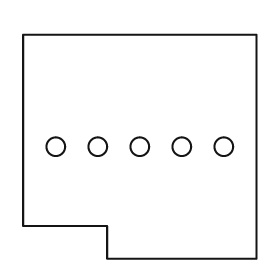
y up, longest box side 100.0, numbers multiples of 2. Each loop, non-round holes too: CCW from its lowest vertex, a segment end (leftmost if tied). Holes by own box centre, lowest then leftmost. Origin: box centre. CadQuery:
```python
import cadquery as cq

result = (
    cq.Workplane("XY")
    .moveTo(-14.0, -48.0)
    .lineTo(50.0, -48.0)
    .lineTo(50.0, 48.0)
    .lineTo(-50.0, 48.0)
    .lineTo(-50.0, -34.0)
    .lineTo(-14.0, -34.0)
    .close()
    .moveTo(-36.0, 0.0)
    .circle(4.0)
    .moveTo(-18.0, 0.0)
    .circle(4.0)
    .moveTo(0.0, 0.0)
    .circle(4.0)
    .moveTo(18.0, 0.0)
    .circle(4.0)
    .moveTo(36.0, 0.0)
    .circle(4.0)
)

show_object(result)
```